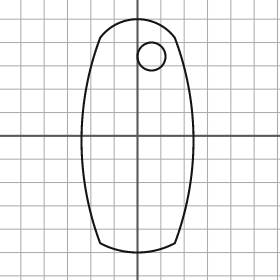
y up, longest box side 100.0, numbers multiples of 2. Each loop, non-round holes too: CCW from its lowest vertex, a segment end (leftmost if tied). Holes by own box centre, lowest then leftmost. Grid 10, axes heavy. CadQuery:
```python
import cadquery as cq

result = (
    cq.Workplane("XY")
    .moveTo(-16.0, -46.0)
    .threePointArc((0.0, -50.0), (16.0, -46.0))
    .threePointArc((24.0, -2.0), (16.0, 42.0))
    .threePointArc((0.0, 50.0), (-16.0, 42.0))
    .threePointArc((-24.0, -2.0), (-16.0, -46.0))
    .close()
    .moveTo(6.0, 34.0)
    .circle(6.0)
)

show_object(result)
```